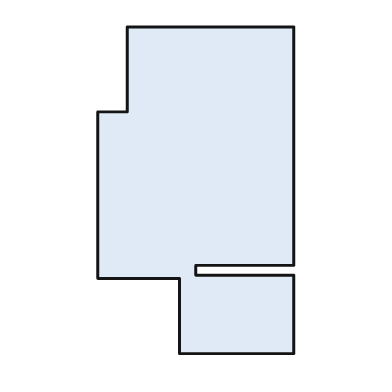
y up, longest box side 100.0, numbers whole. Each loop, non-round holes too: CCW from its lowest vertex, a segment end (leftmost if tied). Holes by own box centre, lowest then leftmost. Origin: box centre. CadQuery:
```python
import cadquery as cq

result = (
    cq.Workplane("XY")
    .moveTo(-5.0, -50.0)
    .lineTo(30.0, -50.0)
    .lineTo(30.0, -26.0)
    .lineTo(0.0, -26.0)
    .lineTo(0.0, -23.0)
    .lineTo(30.0, -23.0)
    .lineTo(30.0, 50.0)
    .lineTo(-21.0, 50.0)
    .lineTo(-21.0, 24.0)
    .lineTo(-30.0, 24.0)
    .lineTo(-30.0, -27.0)
    .lineTo(-5.0, -27.0)
    .close()
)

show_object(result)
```